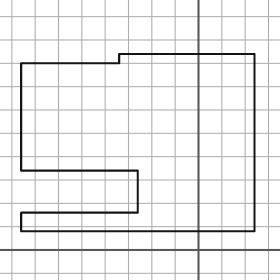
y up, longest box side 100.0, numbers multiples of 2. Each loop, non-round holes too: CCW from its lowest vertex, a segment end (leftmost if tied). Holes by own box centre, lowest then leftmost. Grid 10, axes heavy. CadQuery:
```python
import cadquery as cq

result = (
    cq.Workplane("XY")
    .moveTo(-76.0, 8.0)
    .lineTo(24.0, 8.0)
    .lineTo(24.0, 84.0)
    .lineTo(-34.0, 84.0)
    .lineTo(-34.0, 80.0)
    .lineTo(-76.0, 80.0)
    .lineTo(-76.0, 34.0)
    .lineTo(-26.0, 34.0)
    .lineTo(-26.0, 16.0)
    .lineTo(-76.0, 16.0)
    .close()
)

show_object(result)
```